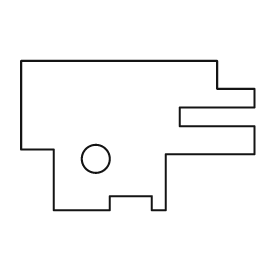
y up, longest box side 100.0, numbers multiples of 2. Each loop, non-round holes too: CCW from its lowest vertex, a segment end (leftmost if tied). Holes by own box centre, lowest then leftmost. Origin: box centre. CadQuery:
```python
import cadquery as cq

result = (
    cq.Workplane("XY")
    .moveTo(-36.0, -32.0)
    .lineTo(-12.0, -32.0)
    .lineTo(-12.0, -26.0)
    .lineTo(6.0, -26.0)
    .lineTo(6.0, -32.0)
    .lineTo(12.0, -32.0)
    .lineTo(12.0, -8.0)
    .lineTo(50.0, -8.0)
    .lineTo(50.0, 4.0)
    .lineTo(18.0, 4.0)
    .lineTo(18.0, 12.0)
    .lineTo(50.0, 12.0)
    .lineTo(50.0, 20.0)
    .lineTo(34.0, 20.0)
    .lineTo(34.0, 32.0)
    .lineTo(-50.0, 32.0)
    .lineTo(-50.0, -6.0)
    .lineTo(-36.0, -6.0)
    .close()
    .moveTo(-18.0, -10.0)
    .circle(6.0)
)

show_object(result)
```